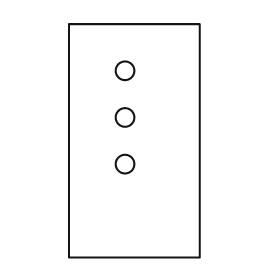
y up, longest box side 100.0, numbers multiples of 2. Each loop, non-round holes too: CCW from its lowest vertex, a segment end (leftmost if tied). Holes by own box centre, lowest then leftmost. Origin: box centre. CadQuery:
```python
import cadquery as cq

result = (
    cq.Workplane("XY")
    .moveTo(-28.0, -50.0)
    .lineTo(28.0, -50.0)
    .lineTo(28.0, 50.0)
    .lineTo(-28.0, 50.0)
    .close()
    .moveTo(-4.0, -10.0)
    .circle(4.0)
    .moveTo(-4.0, 10.0)
    .circle(4.0)
    .moveTo(-4.0, 30.0)
    .circle(4.0)
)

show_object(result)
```